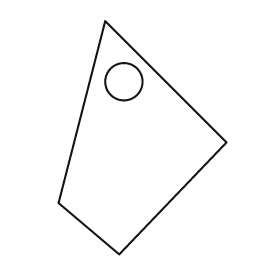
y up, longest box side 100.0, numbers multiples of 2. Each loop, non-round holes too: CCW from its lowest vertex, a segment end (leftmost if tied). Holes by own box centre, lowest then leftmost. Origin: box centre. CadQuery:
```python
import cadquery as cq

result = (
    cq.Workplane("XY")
    .moveTo(-10.0, -50.0)
    .lineTo(36.0, -2.0)
    .lineTo(-16.0, 50.0)
    .lineTo(-36.0, -28.0)
    .close()
    .moveTo(-8.0, 24.0)
    .circle(8.0)
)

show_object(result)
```